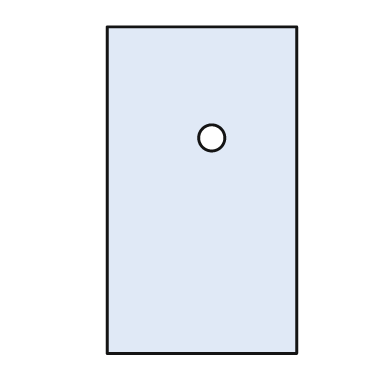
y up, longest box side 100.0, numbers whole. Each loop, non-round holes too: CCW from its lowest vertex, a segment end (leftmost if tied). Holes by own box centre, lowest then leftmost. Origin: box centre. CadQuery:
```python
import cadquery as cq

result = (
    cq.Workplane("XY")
    .moveTo(-29.0, -50.0)
    .lineTo(29.0, -50.0)
    .lineTo(29.0, 50.0)
    .lineTo(-29.0, 50.0)
    .close()
    .moveTo(3.0, 16.0)
    .circle(4.0)
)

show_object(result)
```